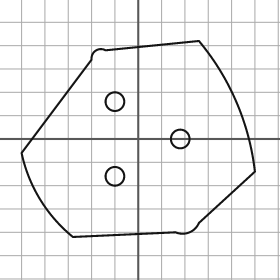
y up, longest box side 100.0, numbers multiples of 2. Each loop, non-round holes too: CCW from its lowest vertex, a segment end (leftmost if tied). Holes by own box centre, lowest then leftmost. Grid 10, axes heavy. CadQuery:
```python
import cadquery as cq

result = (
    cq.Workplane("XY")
    .moveTo(-28.0, -42.0)
    .lineTo(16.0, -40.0)
    .threePointArc((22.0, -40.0), (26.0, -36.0))
    .lineTo(50.0, -14.0)
    .threePointArc((42.0, 16.0), (26.0, 42.0))
    .lineTo(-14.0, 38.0)
    .threePointArc((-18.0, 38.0), (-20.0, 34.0))
    .lineTo(-50.0, -6.0)
    .threePointArc((-42.0, -26.0), (-28.0, -42.0))
    .close()
    .moveTo(-10.0, -16.0)
    .circle(4.0)
    .moveTo(18.0, 0.0)
    .circle(4.0)
    .moveTo(-10.0, 16.0)
    .circle(4.0)
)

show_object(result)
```